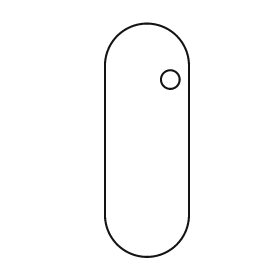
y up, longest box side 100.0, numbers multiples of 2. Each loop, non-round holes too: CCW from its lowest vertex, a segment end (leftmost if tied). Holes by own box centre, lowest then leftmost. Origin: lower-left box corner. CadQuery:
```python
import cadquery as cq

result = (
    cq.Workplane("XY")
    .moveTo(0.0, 18.0)
    .threePointArc((18.0, 0.0), (36.0, 18.0))
    .lineTo(36.0, 82.0)
    .threePointArc((18.0, 100.0), (0.0, 82.0))
    .close()
    .moveTo(28.0, 76.0)
    .circle(4.0)
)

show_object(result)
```